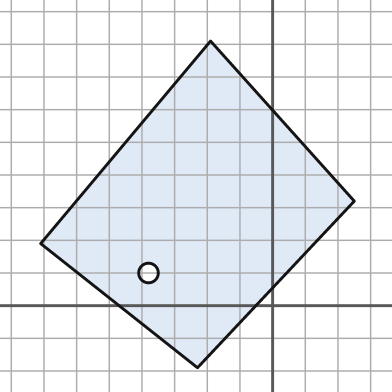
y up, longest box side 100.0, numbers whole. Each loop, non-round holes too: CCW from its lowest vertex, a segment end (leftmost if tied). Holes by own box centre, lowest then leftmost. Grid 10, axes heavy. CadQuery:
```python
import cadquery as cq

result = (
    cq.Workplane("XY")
    .moveTo(-23.0, -19.0)
    .lineTo(25.0, 32.0)
    .lineTo(-19.0, 81.0)
    .lineTo(-71.0, 19.0)
    .close()
    .moveTo(-38.0, 10.0)
    .circle(3.0)
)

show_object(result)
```